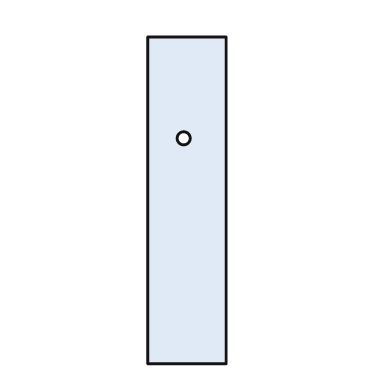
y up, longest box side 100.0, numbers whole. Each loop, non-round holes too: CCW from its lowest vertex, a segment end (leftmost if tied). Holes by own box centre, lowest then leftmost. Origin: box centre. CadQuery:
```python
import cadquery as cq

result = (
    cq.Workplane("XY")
    .moveTo(-12.0, -50.0)
    .lineTo(12.0, -50.0)
    .lineTo(12.0, 50.0)
    .lineTo(-12.0, 50.0)
    .close()
    .moveTo(-1.0, 19.0)
    .circle(2.0)
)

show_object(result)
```